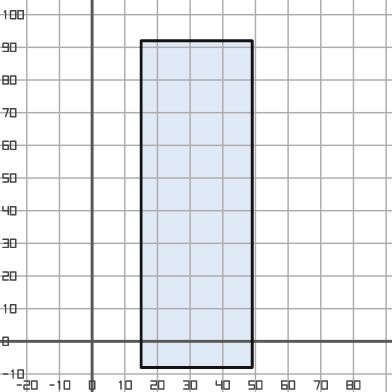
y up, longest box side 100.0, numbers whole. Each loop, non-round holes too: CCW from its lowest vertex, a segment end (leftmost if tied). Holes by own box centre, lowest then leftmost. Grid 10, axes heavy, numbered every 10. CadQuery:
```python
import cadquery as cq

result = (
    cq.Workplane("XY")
    .moveTo(15.0, -8.0)
    .lineTo(49.0, -8.0)
    .lineTo(49.0, 92.0)
    .lineTo(15.0, 92.0)
    .close()
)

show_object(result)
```